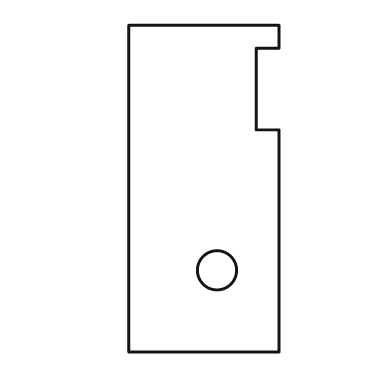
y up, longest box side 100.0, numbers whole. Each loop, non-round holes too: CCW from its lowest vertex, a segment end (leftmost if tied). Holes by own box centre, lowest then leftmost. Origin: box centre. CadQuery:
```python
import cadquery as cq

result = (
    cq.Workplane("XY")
    .moveTo(-23.0, -50.0)
    .lineTo(23.0, -50.0)
    .lineTo(23.0, 18.0)
    .lineTo(16.0, 18.0)
    .lineTo(16.0, 43.0)
    .lineTo(23.0, 43.0)
    .lineTo(23.0, 50.0)
    .lineTo(-23.0, 50.0)
    .close()
    .moveTo(4.0, -25.0)
    .circle(6.0)
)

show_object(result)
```